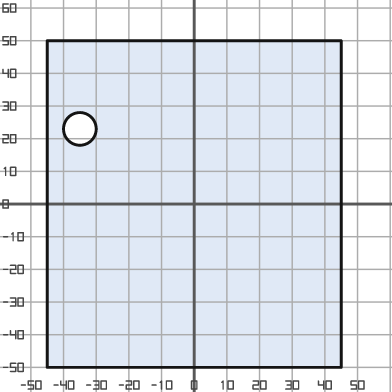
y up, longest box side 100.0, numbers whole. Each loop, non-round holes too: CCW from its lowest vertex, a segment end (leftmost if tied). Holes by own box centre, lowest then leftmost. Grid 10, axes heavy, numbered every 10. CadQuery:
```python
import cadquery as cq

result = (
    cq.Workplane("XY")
    .moveTo(-45.0, -50.0)
    .lineTo(45.0, -50.0)
    .lineTo(45.0, 50.0)
    .lineTo(-45.0, 50.0)
    .close()
    .moveTo(-35.0, 23.0)
    .circle(5.0)
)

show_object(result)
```